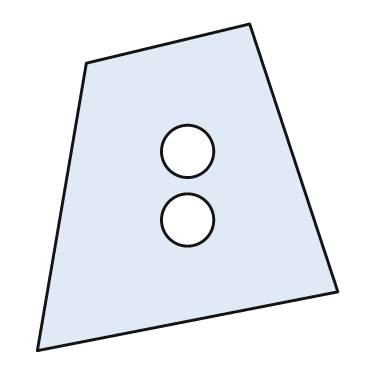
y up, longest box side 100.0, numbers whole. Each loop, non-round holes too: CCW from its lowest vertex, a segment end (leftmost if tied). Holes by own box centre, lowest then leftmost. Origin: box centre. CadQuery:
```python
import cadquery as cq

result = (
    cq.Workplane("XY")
    .moveTo(-46.0, -50.0)
    .lineTo(46.0, -32.0)
    .lineTo(19.0, 50.0)
    .lineTo(-31.0, 38.0)
    .close()
    .moveTo(0.0, -10.0)
    .circle(8.0)
    .moveTo(0.0, 11.0)
    .circle(8.0)
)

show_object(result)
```